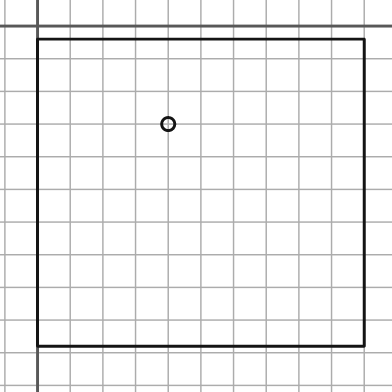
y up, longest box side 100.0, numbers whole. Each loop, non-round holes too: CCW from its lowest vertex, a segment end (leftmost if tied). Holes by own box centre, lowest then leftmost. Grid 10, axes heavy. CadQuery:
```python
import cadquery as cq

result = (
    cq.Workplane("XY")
    .moveTo(0.0, -98.0)
    .lineTo(100.0, -98.0)
    .lineTo(100.0, -4.0)
    .lineTo(0.0, -4.0)
    .close()
    .moveTo(40.0, -30.0)
    .circle(2.0)
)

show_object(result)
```